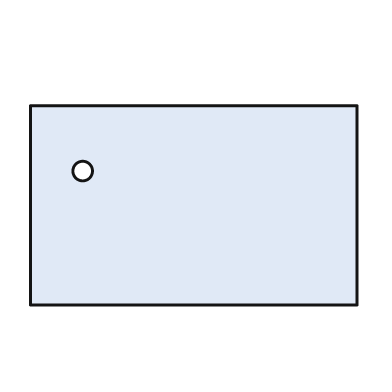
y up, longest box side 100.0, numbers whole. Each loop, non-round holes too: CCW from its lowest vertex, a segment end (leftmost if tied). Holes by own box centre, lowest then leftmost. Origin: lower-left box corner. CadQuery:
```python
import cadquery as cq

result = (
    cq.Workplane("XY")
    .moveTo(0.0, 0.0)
    .lineTo(100.0, 0.0)
    .lineTo(100.0, 61.0)
    .lineTo(0.0, 61.0)
    .close()
    .moveTo(16.0, 41.0)
    .circle(3.0)
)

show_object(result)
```